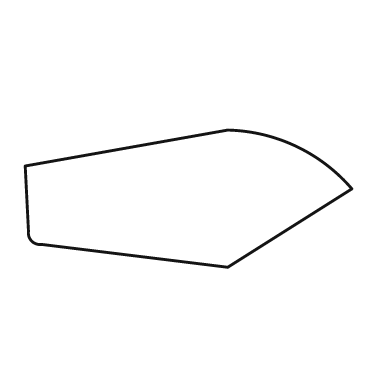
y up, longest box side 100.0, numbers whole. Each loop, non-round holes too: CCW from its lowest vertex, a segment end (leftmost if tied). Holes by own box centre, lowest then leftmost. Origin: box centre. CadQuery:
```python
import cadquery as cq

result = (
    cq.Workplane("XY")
    .moveTo(12.0, -21.0)
    .lineTo(50.0, 3.0)
    .threePointArc((33.0, 16.0), (12.0, 21.0))
    .lineTo(-50.0, 10.0)
    .lineTo(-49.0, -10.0)
    .threePointArc((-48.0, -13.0), (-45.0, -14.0))
    .close()
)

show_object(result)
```